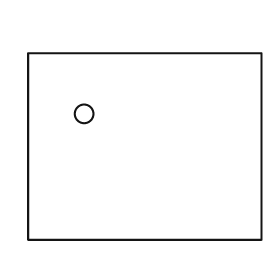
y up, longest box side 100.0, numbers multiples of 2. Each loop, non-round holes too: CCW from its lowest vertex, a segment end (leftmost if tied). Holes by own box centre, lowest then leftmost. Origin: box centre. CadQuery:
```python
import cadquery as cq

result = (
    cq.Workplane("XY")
    .moveTo(-50.0, -40.0)
    .lineTo(50.0, -40.0)
    .lineTo(50.0, 40.0)
    .lineTo(-50.0, 40.0)
    .close()
    .moveTo(-26.0, 14.0)
    .circle(4.0)
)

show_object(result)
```